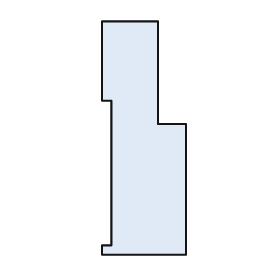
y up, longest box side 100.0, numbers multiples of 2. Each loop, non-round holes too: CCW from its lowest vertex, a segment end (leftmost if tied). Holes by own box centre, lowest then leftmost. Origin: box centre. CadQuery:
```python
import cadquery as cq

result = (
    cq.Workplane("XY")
    .moveTo(-18.0, -50.0)
    .lineTo(18.0, -50.0)
    .lineTo(18.0, 6.0)
    .lineTo(6.0, 6.0)
    .lineTo(6.0, 50.0)
    .lineTo(-18.0, 50.0)
    .lineTo(-18.0, 16.0)
    .lineTo(-14.0, 16.0)
    .lineTo(-14.0, -46.0)
    .lineTo(-18.0, -46.0)
    .close()
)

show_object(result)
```